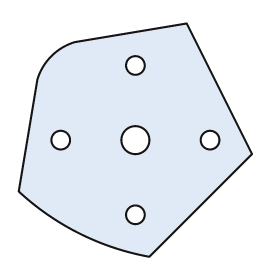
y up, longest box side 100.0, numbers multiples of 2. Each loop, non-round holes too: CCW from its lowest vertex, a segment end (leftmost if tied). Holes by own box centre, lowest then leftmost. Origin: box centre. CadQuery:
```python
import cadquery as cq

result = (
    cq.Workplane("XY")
    .moveTo(6.0, -50.0)
    .lineTo(50.0, -6.0)
    .lineTo(22.0, 50.0)
    .lineTo(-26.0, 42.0)
    .threePointArc((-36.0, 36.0), (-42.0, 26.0))
    .lineTo(-50.0, -22.0)
    .threePointArc((-24.0, -40.0), (6.0, -50.0))
    .close()
    .moveTo(0.0, -32.0)
    .circle(4.0)
    .moveTo(-32.0, 0.0)
    .circle(4.0)
    .moveTo(0.0, 0.0)
    .circle(6.0)
    .moveTo(32.0, 0.0)
    .circle(4.0)
    .moveTo(0.0, 32.0)
    .circle(4.0)
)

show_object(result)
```